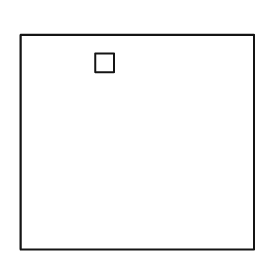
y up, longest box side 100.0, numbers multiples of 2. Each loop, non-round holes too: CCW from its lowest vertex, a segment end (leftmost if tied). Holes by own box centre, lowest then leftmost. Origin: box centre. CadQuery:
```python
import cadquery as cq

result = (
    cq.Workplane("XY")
    .moveTo(-50.0, -46.0)
    .lineTo(50.0, -46.0)
    .lineTo(50.0, 46.0)
    .lineTo(-50.0, 46.0)
    .close()
    .moveTo(-18.0, 30.0)
    .lineTo(-10.0, 30.0)
    .lineTo(-10.0, 38.0)
    .lineTo(-18.0, 38.0)
    .close()
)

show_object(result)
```